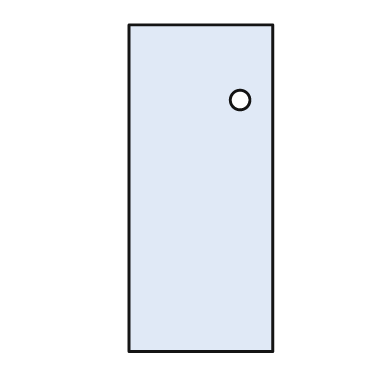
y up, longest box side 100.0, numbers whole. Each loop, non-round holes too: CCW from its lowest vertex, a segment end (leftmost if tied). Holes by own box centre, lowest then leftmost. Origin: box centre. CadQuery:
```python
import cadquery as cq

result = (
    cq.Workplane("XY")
    .moveTo(-22.0, -50.0)
    .lineTo(22.0, -50.0)
    .lineTo(22.0, 50.0)
    .lineTo(-22.0, 50.0)
    .close()
    .moveTo(12.0, 27.0)
    .circle(3.0)
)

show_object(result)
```